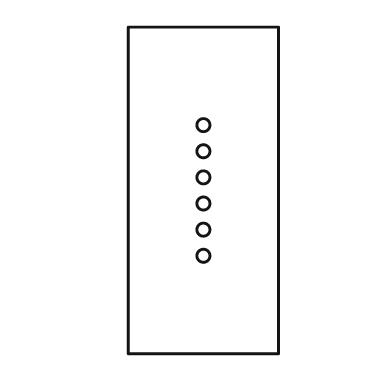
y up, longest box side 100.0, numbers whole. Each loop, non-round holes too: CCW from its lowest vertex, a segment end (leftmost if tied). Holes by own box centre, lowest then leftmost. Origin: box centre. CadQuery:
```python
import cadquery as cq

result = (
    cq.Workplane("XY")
    .moveTo(-23.0, -50.0)
    .lineTo(23.0, -50.0)
    .lineTo(23.0, 50.0)
    .lineTo(-23.0, 50.0)
    .close()
    .moveTo(0.0, -20.0)
    .circle(2.0)
    .moveTo(0.0, -12.0)
    .circle(2.0)
    .moveTo(0.0, -4.0)
    .circle(2.0)
    .moveTo(0.0, 4.0)
    .circle(2.0)
    .moveTo(0.0, 12.0)
    .circle(2.0)
    .moveTo(0.0, 20.0)
    .circle(2.0)
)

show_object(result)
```